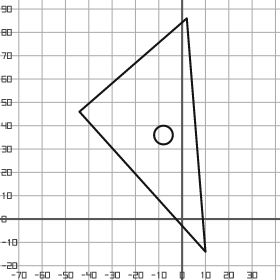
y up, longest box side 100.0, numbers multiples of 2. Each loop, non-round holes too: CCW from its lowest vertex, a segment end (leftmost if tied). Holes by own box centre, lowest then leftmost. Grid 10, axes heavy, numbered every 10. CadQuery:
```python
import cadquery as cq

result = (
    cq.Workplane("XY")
    .moveTo(10.0, -14.0)
    .lineTo(2.0, 86.0)
    .lineTo(-44.0, 46.0)
    .close()
    .moveTo(-8.0, 36.0)
    .circle(4.0)
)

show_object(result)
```